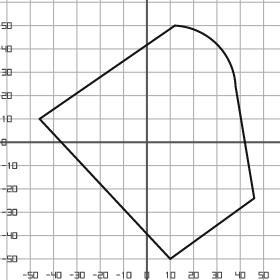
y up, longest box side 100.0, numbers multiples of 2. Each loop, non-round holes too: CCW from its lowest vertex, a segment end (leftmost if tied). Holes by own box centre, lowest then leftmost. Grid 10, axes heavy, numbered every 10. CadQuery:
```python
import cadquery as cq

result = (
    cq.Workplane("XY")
    .moveTo(10.0, -50.0)
    .lineTo(46.0, -24.0)
    .lineTo(38.0, 24.0)
    .threePointArc((30.0, 42.0), (12.0, 50.0))
    .lineTo(-46.0, 10.0)
    .close()
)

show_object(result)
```